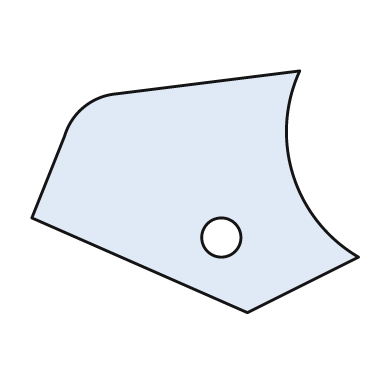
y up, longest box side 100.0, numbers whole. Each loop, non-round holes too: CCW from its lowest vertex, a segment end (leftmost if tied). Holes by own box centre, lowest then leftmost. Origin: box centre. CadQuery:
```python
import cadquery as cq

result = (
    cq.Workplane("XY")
    .moveTo(16.0, -37.0)
    .lineTo(50.0, -20.0)
    .threePointArc((30.0, 5.0), (32.0, 37.0))
    .lineTo(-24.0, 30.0)
    .threePointArc((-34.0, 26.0), (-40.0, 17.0))
    .lineTo(-50.0, -8.0)
    .close()
    .moveTo(8.0, -14.0)
    .circle(6.0)
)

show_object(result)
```